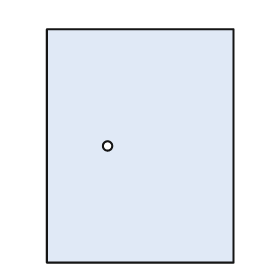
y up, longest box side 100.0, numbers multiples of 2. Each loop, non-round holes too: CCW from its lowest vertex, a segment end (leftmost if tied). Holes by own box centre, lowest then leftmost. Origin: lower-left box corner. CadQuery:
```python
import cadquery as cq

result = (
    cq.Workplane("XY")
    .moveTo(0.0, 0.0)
    .lineTo(80.0, 0.0)
    .lineTo(80.0, 100.0)
    .lineTo(0.0, 100.0)
    .close()
    .moveTo(26.0, 50.0)
    .circle(2.0)
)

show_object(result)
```